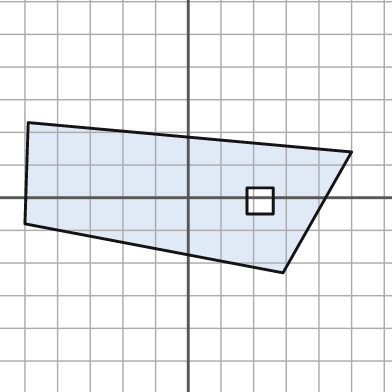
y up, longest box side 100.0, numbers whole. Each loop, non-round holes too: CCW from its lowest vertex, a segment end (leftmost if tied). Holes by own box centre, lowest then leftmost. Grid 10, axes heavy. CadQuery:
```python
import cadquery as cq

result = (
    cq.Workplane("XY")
    .moveTo(29.0, -23.0)
    .lineTo(50.0, 14.0)
    .lineTo(-49.0, 23.0)
    .lineTo(-50.0, -8.0)
    .close()
    .moveTo(18.0, -5.0)
    .lineTo(26.0, -5.0)
    .lineTo(26.0, 3.0)
    .lineTo(18.0, 3.0)
    .close()
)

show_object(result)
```